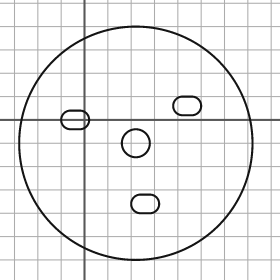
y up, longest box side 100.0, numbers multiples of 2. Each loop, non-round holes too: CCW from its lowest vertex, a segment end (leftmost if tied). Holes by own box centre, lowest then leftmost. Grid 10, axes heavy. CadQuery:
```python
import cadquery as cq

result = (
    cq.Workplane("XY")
    .moveTo(22.0, -10.0)
    .circle(50.0)
    .moveTo(24.0, -40.0)
    .lineTo(28.0, -40.0)
    .threePointArc((32.0, -36.0), (28.0, -32.0))
    .lineTo(24.0, -32.0)
    .threePointArc((20.0, -36.0), (24.0, -40.0))
    .close()
    .moveTo(22.0, -10.0)
    .circle(6.0)
    .moveTo(-6.0, -4.0)
    .lineTo(-2.0, -4.0)
    .threePointArc((2.0, 0.0), (-2.0, 4.0))
    .lineTo(-6.0, 4.0)
    .threePointArc((-10.0, 0.0), (-6.0, -4.0))
    .close()
    .moveTo(42.0, 2.0)
    .lineTo(46.0, 2.0)
    .threePointArc((50.0, 6.0), (46.0, 10.0))
    .lineTo(42.0, 10.0)
    .threePointArc((38.0, 6.0), (42.0, 2.0))
    .close()
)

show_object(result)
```